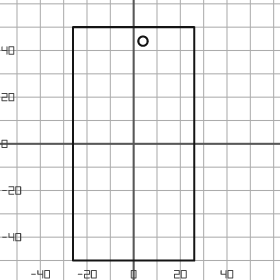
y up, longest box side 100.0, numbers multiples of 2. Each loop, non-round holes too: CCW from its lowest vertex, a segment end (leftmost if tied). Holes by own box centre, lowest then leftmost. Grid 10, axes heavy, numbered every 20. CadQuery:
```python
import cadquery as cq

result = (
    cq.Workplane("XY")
    .moveTo(-26.0, -50.0)
    .lineTo(26.0, -50.0)
    .lineTo(26.0, 50.0)
    .lineTo(-26.0, 50.0)
    .close()
    .moveTo(4.0, 44.0)
    .circle(2.0)
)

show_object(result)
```